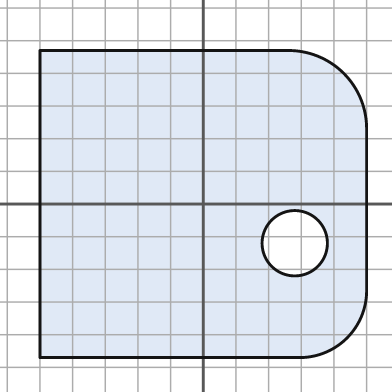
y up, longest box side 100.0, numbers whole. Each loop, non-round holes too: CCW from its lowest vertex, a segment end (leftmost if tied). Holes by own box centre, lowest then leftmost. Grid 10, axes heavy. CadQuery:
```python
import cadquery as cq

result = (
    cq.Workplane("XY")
    .moveTo(-50.0, -47.0)
    .lineTo(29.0, -47.0)
    .threePointArc((44.0, -41.0), (50.0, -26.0))
    .lineTo(50.0, 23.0)
    .threePointArc((43.0, 40.0), (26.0, 47.0))
    .lineTo(-50.0, 47.0)
    .close()
    .moveTo(28.0, -12.0)
    .circle(10.0)
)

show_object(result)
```